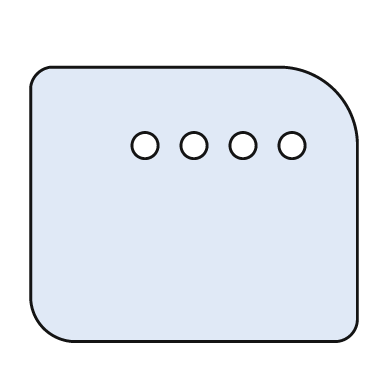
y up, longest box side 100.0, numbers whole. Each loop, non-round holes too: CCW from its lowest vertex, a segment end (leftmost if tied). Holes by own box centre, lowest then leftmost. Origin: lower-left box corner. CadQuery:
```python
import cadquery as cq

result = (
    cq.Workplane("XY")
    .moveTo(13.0, 0.0)
    .lineTo(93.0, 0.0)
    .threePointArc((98.0, 2.0), (100.0, 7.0))
    .lineTo(100.0, 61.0)
    .threePointArc((93.0, 77.0), (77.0, 84.0))
    .lineTo(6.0, 84.0)
    .threePointArc((2.0, 82.0), (0.0, 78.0))
    .lineTo(0.0, 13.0)
    .threePointArc((4.0, 4.0), (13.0, 0.0))
    .close()
    .moveTo(35.0, 60.0)
    .circle(4.0)
    .moveTo(50.0, 60.0)
    .circle(4.0)
    .moveTo(65.0, 60.0)
    .circle(4.0)
    .moveTo(80.0, 60.0)
    .circle(4.0)
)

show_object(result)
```